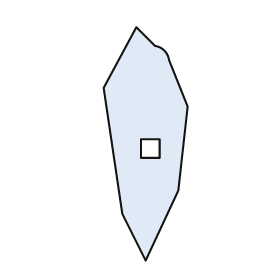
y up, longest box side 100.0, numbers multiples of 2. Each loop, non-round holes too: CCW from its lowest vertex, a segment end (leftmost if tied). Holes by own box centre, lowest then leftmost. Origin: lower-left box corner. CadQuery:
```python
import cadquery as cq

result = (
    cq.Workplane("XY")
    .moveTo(18.0, 0.0)
    .lineTo(32.0, 30.0)
    .lineTo(36.0, 66.0)
    .lineTo(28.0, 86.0)
    .threePointArc((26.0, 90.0), (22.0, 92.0))
    .lineTo(14.0, 100.0)
    .lineTo(0.0, 74.0)
    .lineTo(8.0, 20.0)
    .close()
    .moveTo(16.0, 44.0)
    .lineTo(24.0, 44.0)
    .lineTo(24.0, 52.0)
    .lineTo(16.0, 52.0)
    .close()
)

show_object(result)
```